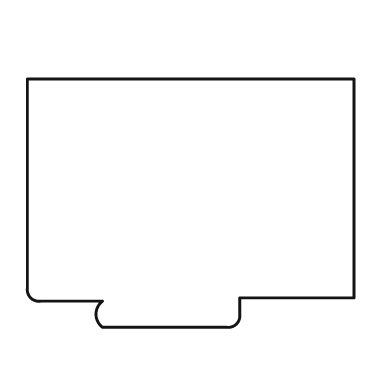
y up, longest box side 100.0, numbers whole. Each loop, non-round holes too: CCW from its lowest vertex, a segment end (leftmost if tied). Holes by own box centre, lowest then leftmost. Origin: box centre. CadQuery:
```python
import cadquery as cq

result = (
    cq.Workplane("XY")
    .moveTo(-27.0, -38.0)
    .lineTo(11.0, -38.0)
    .threePointArc((14.0, -37.0), (15.0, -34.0))
    .lineTo(15.0, -29.0)
    .lineTo(50.0, -29.0)
    .lineTo(50.0, 38.0)
    .lineTo(-50.0, 38.0)
    .lineTo(-50.0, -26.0)
    .threePointArc((-49.0, -29.0), (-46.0, -30.0))
    .lineTo(-27.0, -30.0)
    .threePointArc((-29.0, -34.0), (-27.0, -38.0))
    .close()
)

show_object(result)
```